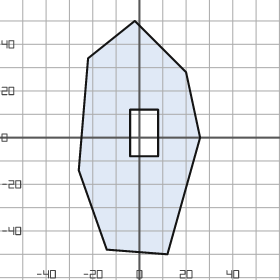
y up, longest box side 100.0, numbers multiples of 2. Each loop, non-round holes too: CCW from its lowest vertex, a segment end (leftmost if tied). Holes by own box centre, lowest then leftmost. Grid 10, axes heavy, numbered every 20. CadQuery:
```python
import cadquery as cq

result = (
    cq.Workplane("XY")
    .moveTo(12.0, -50.0)
    .lineTo(26.0, 0.0)
    .lineTo(20.0, 28.0)
    .lineTo(-2.0, 50.0)
    .lineTo(-22.0, 34.0)
    .lineTo(-26.0, -14.0)
    .lineTo(-14.0, -48.0)
    .close()
    .moveTo(-4.0, -8.0)
    .lineTo(8.0, -8.0)
    .lineTo(8.0, 12.0)
    .lineTo(-4.0, 12.0)
    .close()
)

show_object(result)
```